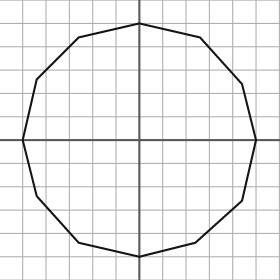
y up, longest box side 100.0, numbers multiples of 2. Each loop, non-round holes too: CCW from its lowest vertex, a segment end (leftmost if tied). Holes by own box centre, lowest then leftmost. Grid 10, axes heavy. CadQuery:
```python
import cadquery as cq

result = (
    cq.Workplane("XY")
    .moveTo(0.0, -50.0)
    .lineTo(24.0, -44.0)
    .lineTo(44.0, -26.0)
    .lineTo(50.0, 0.0)
    .lineTo(44.0, 24.0)
    .lineTo(26.0, 44.0)
    .lineTo(0.0, 50.0)
    .lineTo(-26.0, 44.0)
    .lineTo(-44.0, 26.0)
    .lineTo(-50.0, 0.0)
    .lineTo(-44.0, -24.0)
    .lineTo(-26.0, -44.0)
    .close()
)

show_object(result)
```